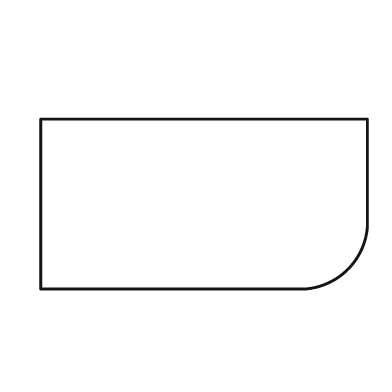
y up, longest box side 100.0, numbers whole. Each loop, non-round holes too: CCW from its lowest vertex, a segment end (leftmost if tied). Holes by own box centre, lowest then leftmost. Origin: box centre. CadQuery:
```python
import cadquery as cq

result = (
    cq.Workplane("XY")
    .moveTo(-50.0, -26.0)
    .lineTo(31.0, -26.0)
    .threePointArc((44.0, -20.0), (50.0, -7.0))
    .lineTo(50.0, 26.0)
    .lineTo(-50.0, 26.0)
    .close()
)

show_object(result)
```